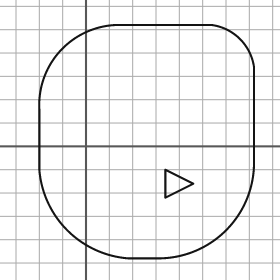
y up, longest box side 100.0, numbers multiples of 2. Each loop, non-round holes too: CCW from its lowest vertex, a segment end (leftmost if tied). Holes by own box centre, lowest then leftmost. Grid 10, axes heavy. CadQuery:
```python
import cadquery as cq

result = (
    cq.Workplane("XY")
    .moveTo(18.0, -48.0)
    .lineTo(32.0, -48.0)
    .threePointArc((60.0, -36.0), (72.0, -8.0))
    .lineTo(72.0, 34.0)
    .threePointArc((66.0, 46.0), (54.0, 52.0))
    .lineTo(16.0, 52.0)
    .threePointArc((-10.0, 42.0), (-20.0, 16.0))
    .lineTo(-20.0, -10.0)
    .threePointArc((-8.0, -36.0), (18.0, -48.0))
    .close()
    .moveTo(34.0, -22.0)
    .lineTo(46.0, -16.0)
    .lineTo(34.0, -10.0)
    .close()
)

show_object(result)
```